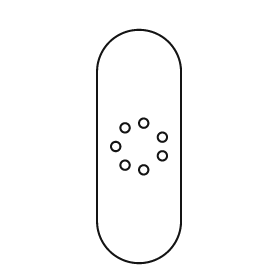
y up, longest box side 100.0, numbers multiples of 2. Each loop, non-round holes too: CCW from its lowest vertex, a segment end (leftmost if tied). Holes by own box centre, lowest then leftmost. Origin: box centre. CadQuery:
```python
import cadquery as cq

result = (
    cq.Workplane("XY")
    .moveTo(-18.0, -32.0)
    .threePointArc((0.0, -50.0), (18.0, -32.0))
    .lineTo(18.0, 32.0)
    .threePointArc((0.0, 50.0), (-18.0, 32.0))
    .close()
    .moveTo(2.0, -10.0)
    .circle(2.0)
    .moveTo(-6.0, -8.0)
    .circle(2.0)
    .moveTo(10.0, -4.0)
    .circle(2.0)
    .moveTo(-10.0, 0.0)
    .circle(2.0)
    .moveTo(10.0, 4.0)
    .circle(2.0)
    .moveTo(-6.0, 8.0)
    .circle(2.0)
    .moveTo(2.0, 10.0)
    .circle(2.0)
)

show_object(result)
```